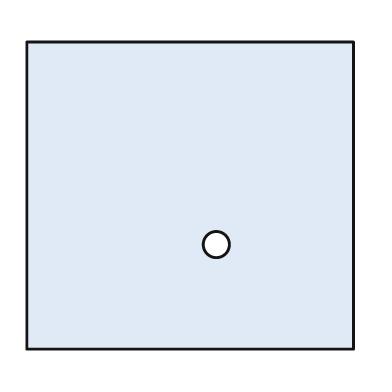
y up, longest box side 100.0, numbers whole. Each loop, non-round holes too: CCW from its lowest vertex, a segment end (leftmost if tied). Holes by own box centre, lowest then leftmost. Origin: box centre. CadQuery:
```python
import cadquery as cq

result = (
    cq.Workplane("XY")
    .moveTo(-50.0, -47.0)
    .lineTo(50.0, -47.0)
    .lineTo(50.0, 47.0)
    .lineTo(-50.0, 47.0)
    .close()
    .moveTo(8.0, -15.0)
    .circle(4.0)
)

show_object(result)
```